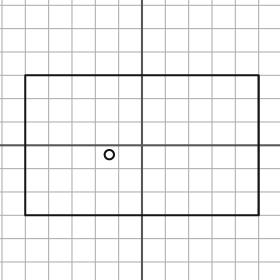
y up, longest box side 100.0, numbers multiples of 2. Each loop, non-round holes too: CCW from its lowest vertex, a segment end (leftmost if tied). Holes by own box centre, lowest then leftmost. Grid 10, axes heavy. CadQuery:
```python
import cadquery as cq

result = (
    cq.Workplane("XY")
    .moveTo(-50.0, -30.0)
    .lineTo(50.0, -30.0)
    .lineTo(50.0, 30.0)
    .lineTo(-50.0, 30.0)
    .close()
    .moveTo(-14.0, -4.0)
    .circle(2.0)
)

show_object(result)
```